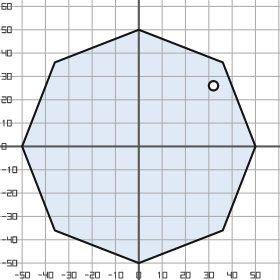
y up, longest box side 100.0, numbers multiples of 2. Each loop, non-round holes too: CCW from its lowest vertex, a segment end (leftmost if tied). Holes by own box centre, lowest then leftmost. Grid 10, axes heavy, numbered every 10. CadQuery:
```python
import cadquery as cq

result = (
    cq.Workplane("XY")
    .moveTo(0.0, -50.0)
    .lineTo(36.0, -36.0)
    .lineTo(50.0, 0.0)
    .lineTo(36.0, 36.0)
    .lineTo(0.0, 50.0)
    .lineTo(-36.0, 36.0)
    .lineTo(-50.0, 0.0)
    .lineTo(-36.0, -36.0)
    .close()
    .moveTo(32.0, 26.0)
    .circle(2.0)
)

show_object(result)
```